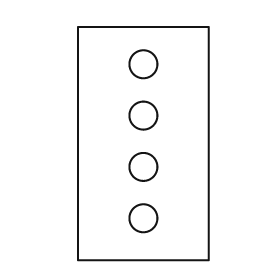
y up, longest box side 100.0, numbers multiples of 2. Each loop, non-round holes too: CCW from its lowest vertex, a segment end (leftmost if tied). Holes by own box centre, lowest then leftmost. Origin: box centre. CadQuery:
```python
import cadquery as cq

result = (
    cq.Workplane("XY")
    .moveTo(-28.0, -50.0)
    .lineTo(28.0, -50.0)
    .lineTo(28.0, 50.0)
    .lineTo(-28.0, 50.0)
    .close()
    .moveTo(0.0, -32.0)
    .circle(6.0)
    .moveTo(0.0, -10.0)
    .circle(6.0)
    .moveTo(0.0, 12.0)
    .circle(6.0)
    .moveTo(0.0, 34.0)
    .circle(6.0)
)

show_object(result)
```